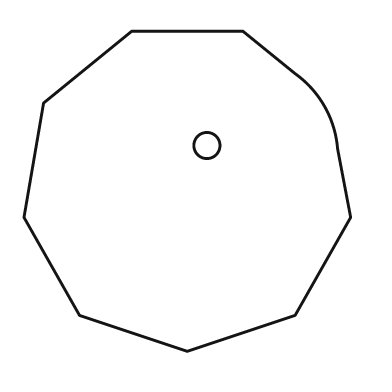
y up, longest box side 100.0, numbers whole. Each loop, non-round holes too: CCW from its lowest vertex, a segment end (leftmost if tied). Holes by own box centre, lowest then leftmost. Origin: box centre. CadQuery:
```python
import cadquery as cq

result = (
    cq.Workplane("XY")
    .moveTo(0.0, -49.0)
    .lineTo(33.0, -38.0)
    .lineTo(50.0, -8.0)
    .lineTo(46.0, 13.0)
    .threePointArc((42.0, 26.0), (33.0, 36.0))
    .lineTo(17.0, 49.0)
    .lineTo(-17.0, 49.0)
    .lineTo(-44.0, 27.0)
    .lineTo(-50.0, -8.0)
    .lineTo(-33.0, -38.0)
    .close()
    .moveTo(6.0, 14.0)
    .circle(4.0)
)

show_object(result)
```